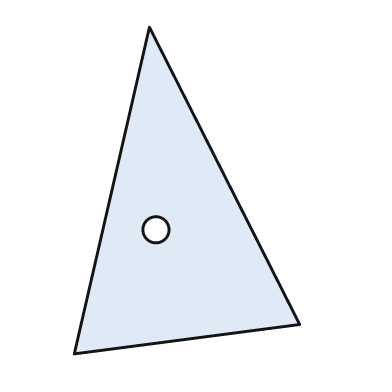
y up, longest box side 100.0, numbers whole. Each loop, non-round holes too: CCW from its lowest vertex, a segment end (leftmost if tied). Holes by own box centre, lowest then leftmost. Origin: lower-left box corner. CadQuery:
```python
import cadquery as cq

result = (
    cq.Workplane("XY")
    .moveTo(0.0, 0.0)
    .lineTo(69.0, 9.0)
    .lineTo(23.0, 100.0)
    .close()
    .moveTo(25.0, 38.0)
    .circle(4.0)
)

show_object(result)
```